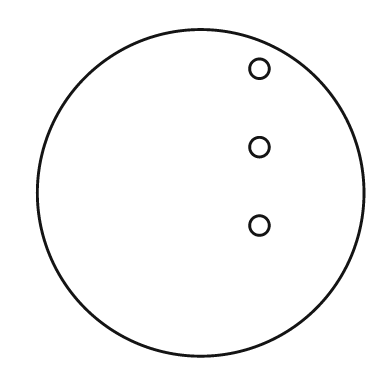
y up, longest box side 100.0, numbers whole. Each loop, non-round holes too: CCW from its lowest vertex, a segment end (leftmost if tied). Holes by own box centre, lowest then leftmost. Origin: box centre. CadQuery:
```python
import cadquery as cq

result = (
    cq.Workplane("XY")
    .moveTo(0.0, 0.0)
    .circle(50.0)
    .moveTo(18.0, -10.0)
    .circle(3.0)
    .moveTo(18.0, 14.0)
    .circle(3.0)
    .moveTo(18.0, 38.0)
    .circle(3.0)
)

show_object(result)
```